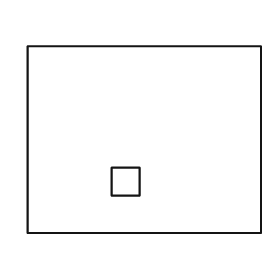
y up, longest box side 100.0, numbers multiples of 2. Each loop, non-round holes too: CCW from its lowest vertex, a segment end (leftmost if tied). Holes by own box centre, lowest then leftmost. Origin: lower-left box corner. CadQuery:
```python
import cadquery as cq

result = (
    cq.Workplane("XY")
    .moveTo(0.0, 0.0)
    .lineTo(100.0, 0.0)
    .lineTo(100.0, 80.0)
    .lineTo(0.0, 80.0)
    .close()
    .moveTo(36.0, 16.0)
    .lineTo(48.0, 16.0)
    .lineTo(48.0, 28.0)
    .lineTo(36.0, 28.0)
    .close()
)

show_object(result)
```